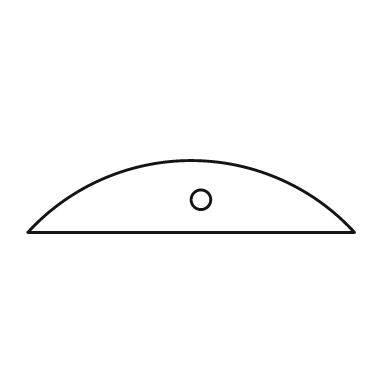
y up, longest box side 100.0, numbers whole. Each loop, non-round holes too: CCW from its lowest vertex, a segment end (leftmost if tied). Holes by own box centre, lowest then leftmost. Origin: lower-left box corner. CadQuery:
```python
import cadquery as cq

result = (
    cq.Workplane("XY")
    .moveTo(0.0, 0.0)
    .lineTo(100.0, 0.0)
    .threePointArc((50.0, 22.0), (0.0, 0.0))
    .close()
    .moveTo(53.0, 10.0)
    .circle(3.0)
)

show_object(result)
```